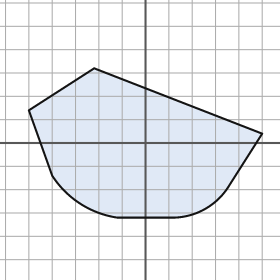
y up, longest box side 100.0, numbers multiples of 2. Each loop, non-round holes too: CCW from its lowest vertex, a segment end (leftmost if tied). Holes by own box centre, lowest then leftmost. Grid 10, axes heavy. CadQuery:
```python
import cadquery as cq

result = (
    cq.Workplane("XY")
    .moveTo(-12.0, -32.0)
    .lineTo(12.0, -32.0)
    .threePointArc((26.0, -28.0), (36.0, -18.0))
    .lineTo(50.0, 4.0)
    .lineTo(-22.0, 32.0)
    .lineTo(-50.0, 14.0)
    .lineTo(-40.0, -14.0)
    .threePointArc((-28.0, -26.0), (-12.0, -32.0))
    .close()
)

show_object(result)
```